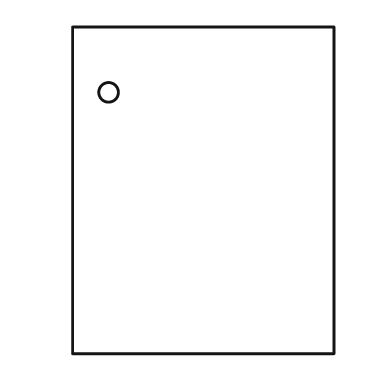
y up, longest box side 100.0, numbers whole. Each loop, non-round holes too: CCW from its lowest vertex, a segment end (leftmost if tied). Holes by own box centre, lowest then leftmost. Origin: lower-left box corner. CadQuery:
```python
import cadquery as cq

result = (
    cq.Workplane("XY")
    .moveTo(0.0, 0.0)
    .lineTo(80.0, 0.0)
    .lineTo(80.0, 100.0)
    .lineTo(0.0, 100.0)
    .close()
    .moveTo(11.0, 80.0)
    .circle(3.0)
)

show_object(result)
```